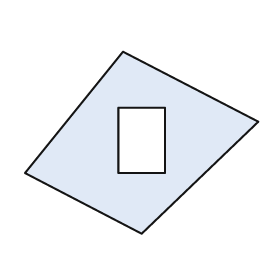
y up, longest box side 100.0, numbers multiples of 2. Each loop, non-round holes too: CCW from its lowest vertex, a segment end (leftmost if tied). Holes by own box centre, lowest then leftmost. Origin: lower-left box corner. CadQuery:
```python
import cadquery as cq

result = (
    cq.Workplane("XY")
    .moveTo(50.0, 0.0)
    .lineTo(100.0, 48.0)
    .lineTo(42.0, 78.0)
    .lineTo(0.0, 26.0)
    .close()
    .moveTo(40.0, 26.0)
    .lineTo(60.0, 26.0)
    .lineTo(60.0, 54.0)
    .lineTo(40.0, 54.0)
    .close()
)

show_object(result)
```